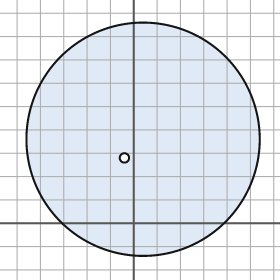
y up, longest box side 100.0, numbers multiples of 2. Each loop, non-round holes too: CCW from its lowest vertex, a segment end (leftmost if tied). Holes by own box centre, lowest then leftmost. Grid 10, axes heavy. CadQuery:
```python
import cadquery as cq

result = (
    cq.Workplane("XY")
    .moveTo(4.0, 36.0)
    .circle(50.0)
    .moveTo(-4.0, 28.0)
    .circle(2.0)
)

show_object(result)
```